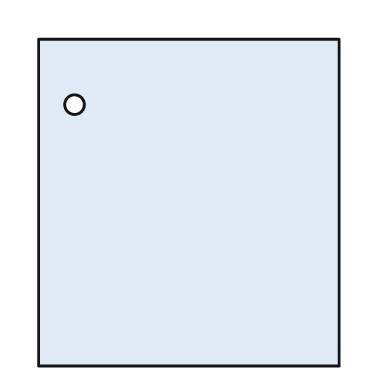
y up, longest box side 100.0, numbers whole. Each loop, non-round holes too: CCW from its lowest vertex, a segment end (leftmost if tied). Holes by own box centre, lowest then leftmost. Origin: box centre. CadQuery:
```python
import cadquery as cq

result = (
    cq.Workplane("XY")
    .moveTo(-46.0, -50.0)
    .lineTo(46.0, -50.0)
    .lineTo(46.0, 50.0)
    .lineTo(-46.0, 50.0)
    .close()
    .moveTo(-35.0, 30.0)
    .circle(3.0)
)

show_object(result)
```